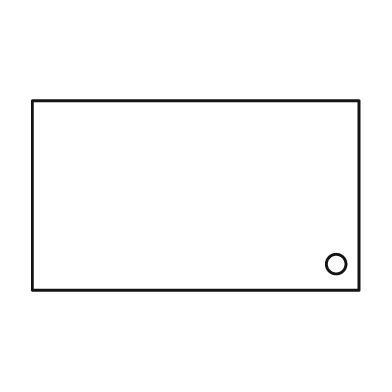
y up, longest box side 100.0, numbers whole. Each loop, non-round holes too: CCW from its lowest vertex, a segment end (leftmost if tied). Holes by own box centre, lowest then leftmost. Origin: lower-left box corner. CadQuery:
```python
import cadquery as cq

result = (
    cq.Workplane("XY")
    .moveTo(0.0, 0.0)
    .lineTo(100.0, 0.0)
    .lineTo(100.0, 58.0)
    .lineTo(0.0, 58.0)
    .close()
    .moveTo(93.0, 8.0)
    .circle(3.0)
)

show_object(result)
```